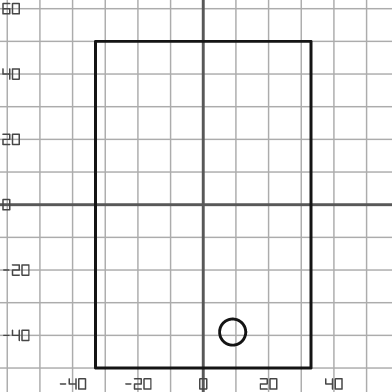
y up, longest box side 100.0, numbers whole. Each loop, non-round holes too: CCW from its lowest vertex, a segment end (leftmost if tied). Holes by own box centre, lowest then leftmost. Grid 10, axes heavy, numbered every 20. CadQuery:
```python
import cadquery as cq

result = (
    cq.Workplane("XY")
    .moveTo(-33.0, -50.0)
    .lineTo(33.0, -50.0)
    .lineTo(33.0, 50.0)
    .lineTo(-33.0, 50.0)
    .close()
    .moveTo(9.0, -39.0)
    .circle(4.0)
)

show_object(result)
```